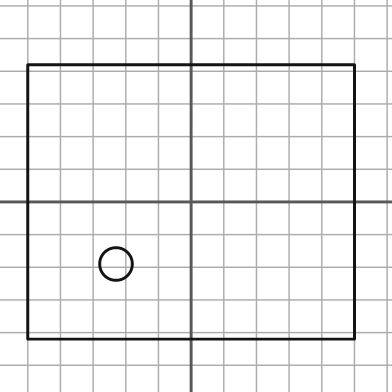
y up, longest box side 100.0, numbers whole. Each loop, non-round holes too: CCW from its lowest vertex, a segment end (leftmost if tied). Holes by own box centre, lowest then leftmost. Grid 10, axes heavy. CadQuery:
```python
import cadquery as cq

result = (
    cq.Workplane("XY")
    .moveTo(-50.0, -42.0)
    .lineTo(50.0, -42.0)
    .lineTo(50.0, 42.0)
    .lineTo(-50.0, 42.0)
    .close()
    .moveTo(-23.0, -19.0)
    .circle(5.0)
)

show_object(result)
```